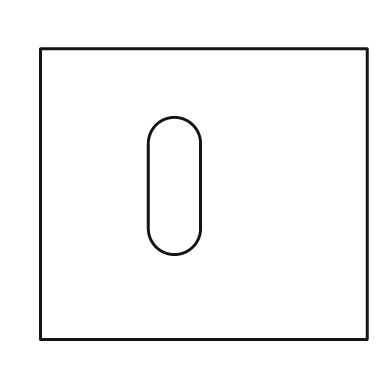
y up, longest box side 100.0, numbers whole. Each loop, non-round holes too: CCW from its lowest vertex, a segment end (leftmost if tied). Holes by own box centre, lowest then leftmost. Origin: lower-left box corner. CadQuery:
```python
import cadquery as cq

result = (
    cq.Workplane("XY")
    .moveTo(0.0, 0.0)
    .lineTo(100.0, 0.0)
    .lineTo(100.0, 89.0)
    .lineTo(0.0, 89.0)
    .close()
    .moveTo(33.0, 34.0)
    .threePointArc((41.0, 26.0), (49.0, 34.0))
    .lineTo(49.0, 60.0)
    .threePointArc((41.0, 68.0), (33.0, 60.0))
    .close()
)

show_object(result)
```